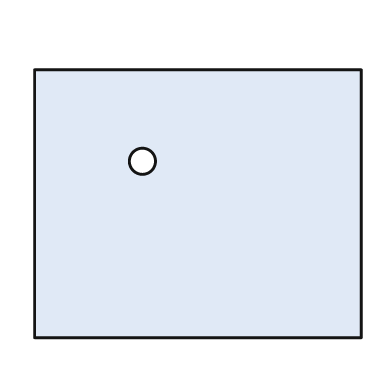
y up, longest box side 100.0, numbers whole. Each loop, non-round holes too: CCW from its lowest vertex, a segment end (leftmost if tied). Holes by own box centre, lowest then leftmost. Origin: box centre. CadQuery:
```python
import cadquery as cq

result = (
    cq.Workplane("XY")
    .moveTo(-50.0, -41.0)
    .lineTo(50.0, -41.0)
    .lineTo(50.0, 41.0)
    .lineTo(-50.0, 41.0)
    .close()
    .moveTo(-17.0, 13.0)
    .circle(4.0)
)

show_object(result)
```